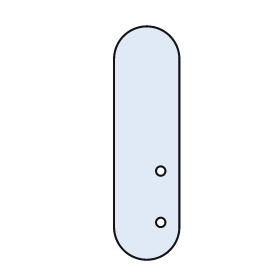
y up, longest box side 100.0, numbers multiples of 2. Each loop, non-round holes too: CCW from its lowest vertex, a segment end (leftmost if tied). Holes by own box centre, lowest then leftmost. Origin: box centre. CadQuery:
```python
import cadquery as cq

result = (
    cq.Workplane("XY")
    .moveTo(-14.0, -36.0)
    .threePointArc((0.0, -50.0), (14.0, -36.0))
    .lineTo(14.0, 36.0)
    .threePointArc((0.0, 50.0), (-14.0, 36.0))
    .close()
    .moveTo(6.0, -34.0)
    .circle(2.0)
    .moveTo(6.0, -12.0)
    .circle(2.0)
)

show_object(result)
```